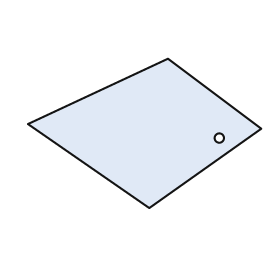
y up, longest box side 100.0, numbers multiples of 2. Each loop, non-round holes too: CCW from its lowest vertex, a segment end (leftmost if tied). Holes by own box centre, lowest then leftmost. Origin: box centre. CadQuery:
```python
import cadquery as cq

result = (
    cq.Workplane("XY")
    .moveTo(2.0, -32.0)
    .lineTo(50.0, 2.0)
    .lineTo(10.0, 32.0)
    .lineTo(-50.0, 4.0)
    .close()
    .moveTo(32.0, -2.0)
    .circle(2.0)
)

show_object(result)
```